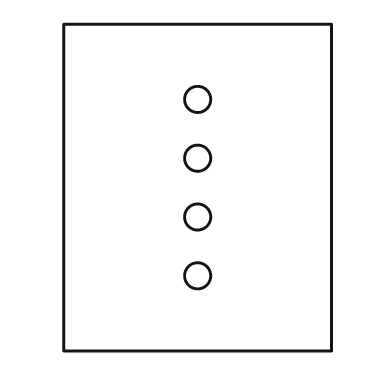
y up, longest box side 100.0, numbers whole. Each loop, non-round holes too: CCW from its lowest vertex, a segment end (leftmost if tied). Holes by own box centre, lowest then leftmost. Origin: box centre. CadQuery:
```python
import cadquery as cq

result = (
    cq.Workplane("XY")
    .moveTo(-41.0, -50.0)
    .lineTo(41.0, -50.0)
    .lineTo(41.0, 50.0)
    .lineTo(-41.0, 50.0)
    .close()
    .moveTo(0.0, -27.0)
    .circle(4.0)
    .moveTo(0.0, -9.0)
    .circle(4.0)
    .moveTo(0.0, 9.0)
    .circle(4.0)
    .moveTo(0.0, 27.0)
    .circle(4.0)
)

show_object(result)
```